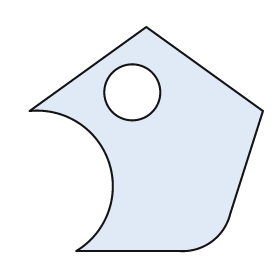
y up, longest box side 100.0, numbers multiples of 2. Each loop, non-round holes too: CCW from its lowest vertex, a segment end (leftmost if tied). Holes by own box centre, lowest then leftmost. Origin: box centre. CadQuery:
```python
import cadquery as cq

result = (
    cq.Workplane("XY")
    .moveTo(-30.0, -48.0)
    .lineTo(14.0, -48.0)
    .threePointArc((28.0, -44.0), (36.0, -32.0))
    .lineTo(50.0, 12.0)
    .lineTo(0.0, 48.0)
    .lineTo(-50.0, 12.0)
    .threePointArc((-16.0, -10.0), (-30.0, -48.0))
    .close()
    .moveTo(-6.0, 20.0)
    .circle(12.0)
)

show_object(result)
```